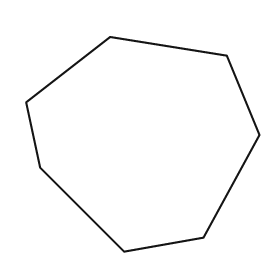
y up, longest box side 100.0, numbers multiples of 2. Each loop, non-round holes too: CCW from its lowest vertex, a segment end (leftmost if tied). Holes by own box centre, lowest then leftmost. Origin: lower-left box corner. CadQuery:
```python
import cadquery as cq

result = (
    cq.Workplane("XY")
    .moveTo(42.0, 0.0)
    .lineTo(76.0, 6.0)
    .lineTo(100.0, 50.0)
    .lineTo(86.0, 84.0)
    .lineTo(36.0, 92.0)
    .lineTo(0.0, 64.0)
    .lineTo(6.0, 36.0)
    .close()
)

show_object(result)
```